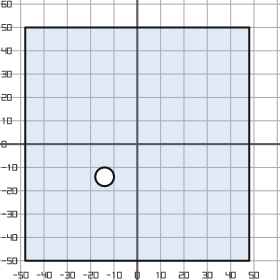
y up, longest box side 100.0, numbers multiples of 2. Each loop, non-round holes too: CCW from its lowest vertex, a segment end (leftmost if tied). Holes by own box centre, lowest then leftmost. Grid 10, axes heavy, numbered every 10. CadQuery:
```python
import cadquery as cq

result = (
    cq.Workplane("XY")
    .moveTo(-48.0, -50.0)
    .lineTo(48.0, -50.0)
    .lineTo(48.0, 50.0)
    .lineTo(-48.0, 50.0)
    .close()
    .moveTo(-14.0, -14.0)
    .circle(4.0)
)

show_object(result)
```